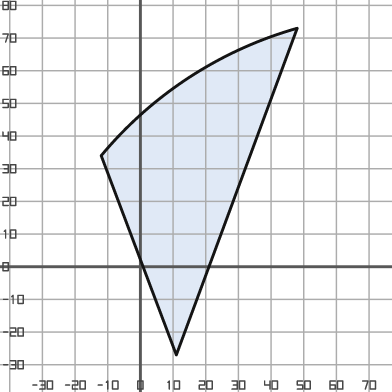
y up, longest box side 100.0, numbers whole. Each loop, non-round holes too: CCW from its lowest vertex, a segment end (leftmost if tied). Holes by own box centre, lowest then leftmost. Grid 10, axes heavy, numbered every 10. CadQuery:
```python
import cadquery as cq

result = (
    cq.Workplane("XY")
    .moveTo(11.0, -27.0)
    .lineTo(48.0, 73.0)
    .threePointArc((15.0, 58.0), (-12.0, 34.0))
    .close()
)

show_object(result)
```